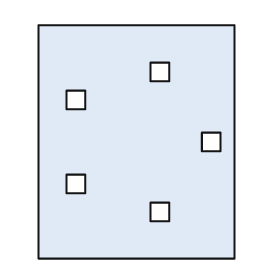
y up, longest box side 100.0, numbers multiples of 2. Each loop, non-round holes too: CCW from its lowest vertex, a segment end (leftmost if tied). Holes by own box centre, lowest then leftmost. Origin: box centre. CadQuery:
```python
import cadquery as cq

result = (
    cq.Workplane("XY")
    .moveTo(-42.0, -50.0)
    .lineTo(42.0, -50.0)
    .lineTo(42.0, 50.0)
    .lineTo(-42.0, 50.0)
    .close()
    .moveTo(6.0, -34.0)
    .lineTo(14.0, -34.0)
    .lineTo(14.0, -26.0)
    .lineTo(6.0, -26.0)
    .close()
    .moveTo(-30.0, -22.0)
    .lineTo(-22.0, -22.0)
    .lineTo(-22.0, -14.0)
    .lineTo(-30.0, -14.0)
    .close()
    .moveTo(28.0, -4.0)
    .lineTo(36.0, -4.0)
    .lineTo(36.0, 4.0)
    .lineTo(28.0, 4.0)
    .close()
    .moveTo(-30.0, 14.0)
    .lineTo(-22.0, 14.0)
    .lineTo(-22.0, 22.0)
    .lineTo(-30.0, 22.0)
    .close()
    .moveTo(6.0, 26.0)
    .lineTo(14.0, 26.0)
    .lineTo(14.0, 34.0)
    .lineTo(6.0, 34.0)
    .close()
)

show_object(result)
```